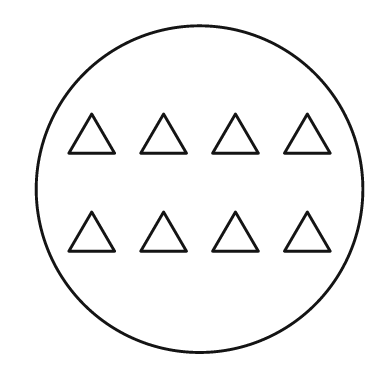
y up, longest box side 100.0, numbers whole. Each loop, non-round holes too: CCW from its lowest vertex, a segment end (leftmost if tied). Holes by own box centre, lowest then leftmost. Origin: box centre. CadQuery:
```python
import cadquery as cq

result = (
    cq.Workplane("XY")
    .moveTo(0.0, 0.0)
    .circle(50.0)
    .moveTo(-40.0, -19.0)
    .lineTo(-26.0, -19.0)
    .lineTo(-33.0, -7.0)
    .close()
    .moveTo(-18.0, -19.0)
    .lineTo(-4.0, -19.0)
    .lineTo(-11.0, -7.0)
    .close()
    .moveTo(4.0, -19.0)
    .lineTo(18.0, -19.0)
    .lineTo(11.0, -7.0)
    .close()
    .moveTo(26.0, -19.0)
    .lineTo(40.0, -19.0)
    .lineTo(33.0, -7.0)
    .close()
    .moveTo(-40.0, 11.0)
    .lineTo(-26.0, 11.0)
    .lineTo(-33.0, 23.0)
    .close()
    .moveTo(-18.0, 11.0)
    .lineTo(-4.0, 11.0)
    .lineTo(-11.0, 23.0)
    .close()
    .moveTo(4.0, 11.0)
    .lineTo(18.0, 11.0)
    .lineTo(11.0, 23.0)
    .close()
    .moveTo(26.0, 11.0)
    .lineTo(40.0, 11.0)
    .lineTo(33.0, 23.0)
    .close()
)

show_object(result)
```